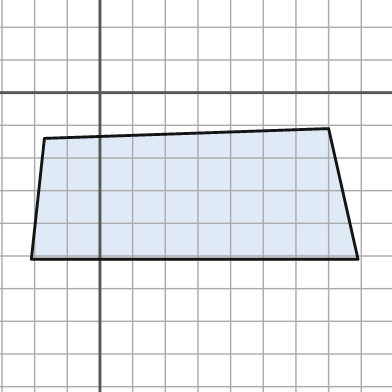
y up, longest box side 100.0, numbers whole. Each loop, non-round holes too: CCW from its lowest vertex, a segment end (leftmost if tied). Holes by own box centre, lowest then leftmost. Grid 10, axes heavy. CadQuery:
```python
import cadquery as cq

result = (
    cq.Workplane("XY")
    .moveTo(-21.0, -51.0)
    .lineTo(79.0, -51.0)
    .lineTo(70.0, -11.0)
    .lineTo(-17.0, -14.0)
    .close()
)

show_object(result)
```